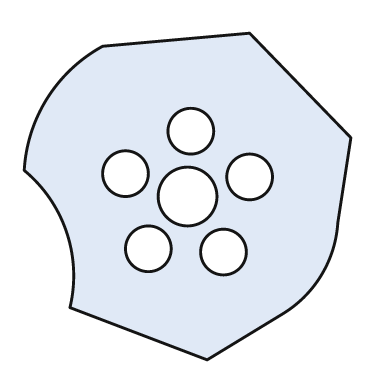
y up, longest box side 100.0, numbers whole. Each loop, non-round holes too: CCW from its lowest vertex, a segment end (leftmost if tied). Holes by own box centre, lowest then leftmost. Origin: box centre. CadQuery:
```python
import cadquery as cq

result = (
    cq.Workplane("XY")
    .moveTo(6.0, -50.0)
    .lineTo(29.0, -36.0)
    .threePointArc((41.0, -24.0), (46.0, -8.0))
    .lineTo(50.0, 18.0)
    .lineTo(19.0, 50.0)
    .lineTo(-26.0, 46.0)
    .threePointArc((-43.0, 30.0), (-50.0, 8.0))
    .threePointArc((-37.0, -11.0), (-36.0, -34.0))
    .close()
    .moveTo(11.0, -17.0)
    .circle(7.0)
    .moveTo(-12.0, -16.0)
    .circle(7.0)
    .moveTo(0.0, 0.0)
    .circle(9.0)
    .moveTo(19.0, 6.0)
    .circle(7.0)
    .moveTo(-19.0, 7.0)
    .circle(7.0)
    .moveTo(1.0, 20.0)
    .circle(7.0)
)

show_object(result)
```